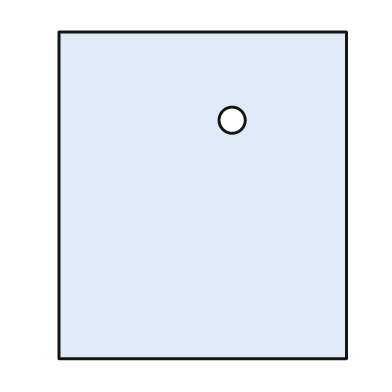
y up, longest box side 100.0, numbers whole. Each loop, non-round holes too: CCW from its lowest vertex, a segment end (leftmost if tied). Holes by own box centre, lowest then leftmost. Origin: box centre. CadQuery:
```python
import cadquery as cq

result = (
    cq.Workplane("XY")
    .moveTo(-44.0, -50.0)
    .lineTo(44.0, -50.0)
    .lineTo(44.0, 50.0)
    .lineTo(-44.0, 50.0)
    .close()
    .moveTo(9.0, 23.0)
    .circle(4.0)
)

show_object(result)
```